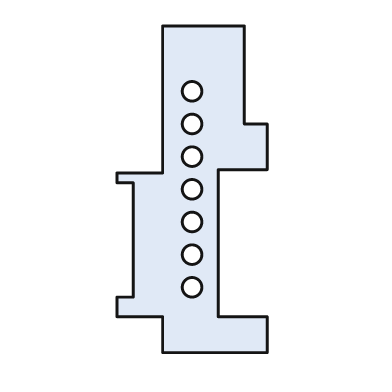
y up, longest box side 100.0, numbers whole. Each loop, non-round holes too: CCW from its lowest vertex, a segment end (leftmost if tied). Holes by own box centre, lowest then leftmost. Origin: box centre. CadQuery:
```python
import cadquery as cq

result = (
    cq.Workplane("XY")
    .moveTo(-9.0, -50.0)
    .lineTo(23.0, -50.0)
    .lineTo(23.0, -39.0)
    .lineTo(8.0, -39.0)
    .lineTo(8.0, 6.0)
    .lineTo(23.0, 6.0)
    .lineTo(23.0, 20.0)
    .lineTo(16.0, 20.0)
    .lineTo(16.0, 50.0)
    .lineTo(-9.0, 50.0)
    .lineTo(-9.0, 5.0)
    .lineTo(-23.0, 5.0)
    .lineTo(-23.0, 2.0)
    .lineTo(-18.0, 2.0)
    .lineTo(-18.0, -33.0)
    .lineTo(-23.0, -33.0)
    .lineTo(-23.0, -39.0)
    .lineTo(-9.0, -39.0)
    .close()
    .moveTo(0.0, -30.0)
    .circle(3.0)
    .moveTo(0.0, -20.0)
    .circle(3.0)
    .moveTo(0.0, -10.0)
    .circle(3.0)
    .moveTo(0.0, 0.0)
    .circle(3.0)
    .moveTo(0.0, 10.0)
    .circle(3.0)
    .moveTo(0.0, 20.0)
    .circle(3.0)
    .moveTo(0.0, 30.0)
    .circle(3.0)
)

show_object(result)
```